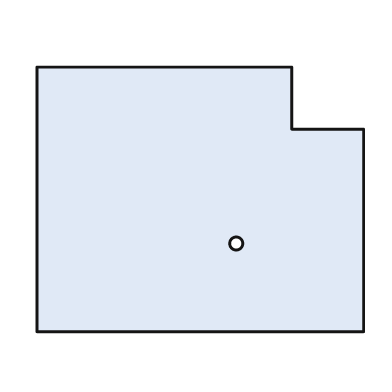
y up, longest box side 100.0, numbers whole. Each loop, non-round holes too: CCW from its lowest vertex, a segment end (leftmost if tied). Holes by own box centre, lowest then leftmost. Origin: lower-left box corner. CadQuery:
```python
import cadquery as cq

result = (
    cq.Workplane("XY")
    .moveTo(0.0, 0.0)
    .lineTo(100.0, 0.0)
    .lineTo(100.0, 62.0)
    .lineTo(78.0, 62.0)
    .lineTo(78.0, 81.0)
    .lineTo(0.0, 81.0)
    .close()
    .moveTo(61.0, 27.0)
    .circle(2.0)
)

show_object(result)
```